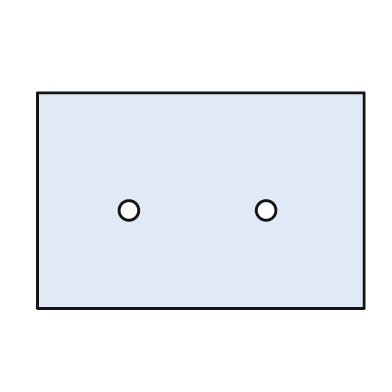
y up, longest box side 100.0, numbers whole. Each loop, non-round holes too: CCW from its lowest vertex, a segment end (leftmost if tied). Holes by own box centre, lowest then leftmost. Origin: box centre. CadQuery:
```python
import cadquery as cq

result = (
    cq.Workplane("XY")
    .moveTo(-50.0, -33.0)
    .lineTo(50.0, -33.0)
    .lineTo(50.0, 33.0)
    .lineTo(-50.0, 33.0)
    .close()
    .moveTo(-22.0, -3.0)
    .circle(3.0)
    .moveTo(20.0, -3.0)
    .circle(3.0)
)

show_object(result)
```